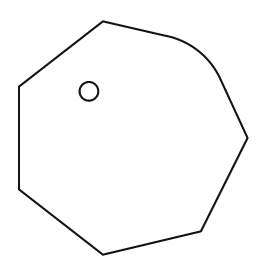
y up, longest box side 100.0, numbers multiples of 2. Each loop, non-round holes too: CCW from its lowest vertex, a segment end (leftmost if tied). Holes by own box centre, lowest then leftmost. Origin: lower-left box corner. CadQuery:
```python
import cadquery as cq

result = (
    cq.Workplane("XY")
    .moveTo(36.0, 0.0)
    .lineTo(78.0, 10.0)
    .lineTo(98.0, 50.0)
    .lineTo(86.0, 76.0)
    .threePointArc((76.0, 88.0), (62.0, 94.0))
    .lineTo(36.0, 100.0)
    .lineTo(0.0, 72.0)
    .lineTo(0.0, 28.0)
    .close()
    .moveTo(30.0, 70.0)
    .circle(4.0)
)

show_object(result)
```